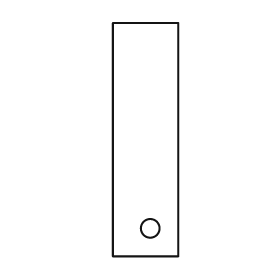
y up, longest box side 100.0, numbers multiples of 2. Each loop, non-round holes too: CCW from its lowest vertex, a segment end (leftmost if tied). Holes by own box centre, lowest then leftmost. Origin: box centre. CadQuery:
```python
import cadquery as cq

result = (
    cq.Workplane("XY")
    .moveTo(-14.0, -50.0)
    .lineTo(14.0, -50.0)
    .lineTo(14.0, 50.0)
    .lineTo(-14.0, 50.0)
    .close()
    .moveTo(2.0, -38.0)
    .circle(4.0)
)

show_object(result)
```